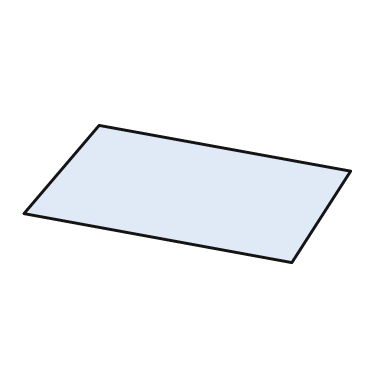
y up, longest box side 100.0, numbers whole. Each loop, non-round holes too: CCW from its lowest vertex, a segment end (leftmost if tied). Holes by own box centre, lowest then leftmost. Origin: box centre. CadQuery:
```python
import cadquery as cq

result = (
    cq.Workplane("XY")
    .moveTo(32.0, -21.0)
    .lineTo(50.0, 7.0)
    .lineTo(-27.0, 21.0)
    .lineTo(-50.0, -6.0)
    .close()
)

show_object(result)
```